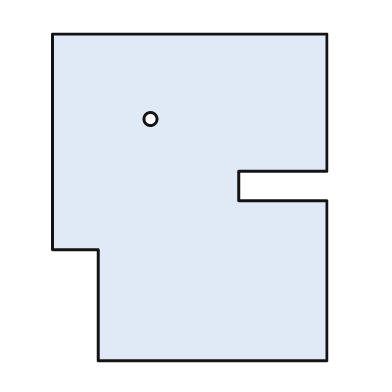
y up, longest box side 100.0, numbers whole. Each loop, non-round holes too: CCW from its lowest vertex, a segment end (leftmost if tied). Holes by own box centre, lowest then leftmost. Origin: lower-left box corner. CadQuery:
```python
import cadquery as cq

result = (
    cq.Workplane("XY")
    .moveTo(14.0, 0.0)
    .lineTo(84.0, 0.0)
    .lineTo(84.0, 49.0)
    .lineTo(57.0, 49.0)
    .lineTo(57.0, 58.0)
    .lineTo(84.0, 58.0)
    .lineTo(84.0, 100.0)
    .lineTo(0.0, 100.0)
    .lineTo(0.0, 34.0)
    .lineTo(14.0, 34.0)
    .close()
    .moveTo(30.0, 74.0)
    .circle(2.0)
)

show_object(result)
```